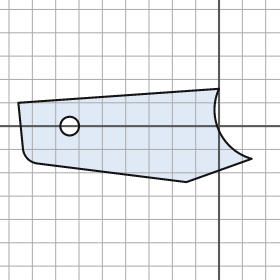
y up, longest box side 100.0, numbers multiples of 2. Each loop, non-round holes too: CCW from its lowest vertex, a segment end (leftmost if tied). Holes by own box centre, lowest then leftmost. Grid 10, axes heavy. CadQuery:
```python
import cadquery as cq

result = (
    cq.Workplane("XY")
    .moveTo(-14.0, -24.0)
    .lineTo(14.0, -14.0)
    .threePointArc((0.0, -2.0), (0.0, 16.0))
    .lineTo(-86.0, 10.0)
    .lineTo(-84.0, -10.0)
    .threePointArc((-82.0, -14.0), (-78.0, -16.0))
    .close()
    .moveTo(-64.0, 0.0)
    .circle(4.0)
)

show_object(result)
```